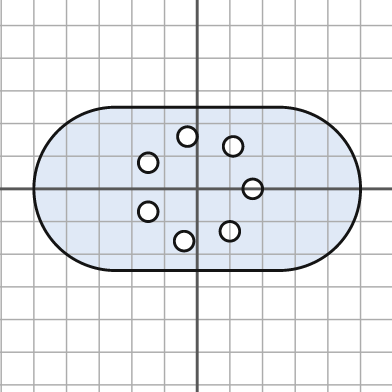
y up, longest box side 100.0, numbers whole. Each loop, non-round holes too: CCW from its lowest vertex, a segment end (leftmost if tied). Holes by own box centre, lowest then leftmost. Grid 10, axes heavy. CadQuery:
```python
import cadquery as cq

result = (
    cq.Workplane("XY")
    .moveTo(-25.0, -25.0)
    .lineTo(25.0, -25.0)
    .threePointArc((50.0, 0.0), (25.0, 25.0))
    .lineTo(-25.0, 25.0)
    .threePointArc((-50.0, 0.0), (-25.0, -25.0))
    .close()
    .moveTo(-4.0, -16.0)
    .circle(3.0)
    .moveTo(10.0, -13.0)
    .circle(3.0)
    .moveTo(-15.0, -7.0)
    .circle(3.0)
    .moveTo(17.0, 0.0)
    .circle(3.0)
    .moveTo(-15.0, 8.0)
    .circle(3.0)
    .moveTo(11.0, 13.0)
    .circle(3.0)
    .moveTo(-3.0, 16.0)
    .circle(3.0)
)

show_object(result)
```